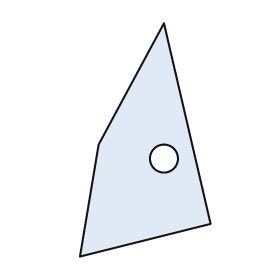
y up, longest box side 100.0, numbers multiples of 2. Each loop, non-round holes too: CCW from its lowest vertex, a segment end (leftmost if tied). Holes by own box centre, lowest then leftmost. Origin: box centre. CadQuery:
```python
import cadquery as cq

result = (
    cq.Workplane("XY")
    .moveTo(-28.0, -50.0)
    .lineTo(28.0, -36.0)
    .lineTo(8.0, 50.0)
    .lineTo(-20.0, -2.0)
    .close()
    .moveTo(8.0, -8.0)
    .circle(6.0)
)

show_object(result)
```